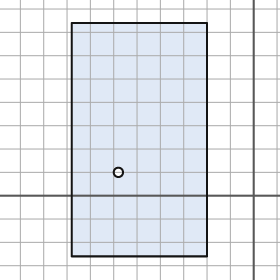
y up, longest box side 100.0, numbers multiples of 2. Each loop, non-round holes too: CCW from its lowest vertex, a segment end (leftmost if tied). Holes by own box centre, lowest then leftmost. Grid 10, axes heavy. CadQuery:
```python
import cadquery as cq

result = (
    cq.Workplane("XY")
    .moveTo(-78.0, -26.0)
    .lineTo(-20.0, -26.0)
    .lineTo(-20.0, 74.0)
    .lineTo(-78.0, 74.0)
    .close()
    .moveTo(-58.0, 10.0)
    .circle(2.0)
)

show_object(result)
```